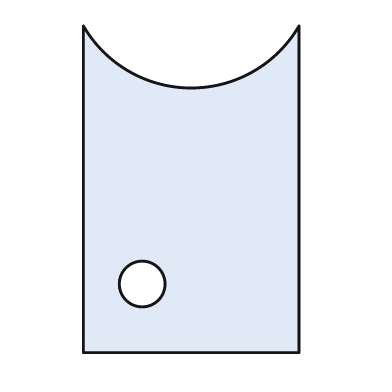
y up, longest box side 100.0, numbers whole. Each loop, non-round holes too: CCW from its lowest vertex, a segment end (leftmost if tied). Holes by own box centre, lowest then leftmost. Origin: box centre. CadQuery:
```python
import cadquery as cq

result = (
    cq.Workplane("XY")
    .moveTo(-33.0, -50.0)
    .lineTo(33.0, -50.0)
    .lineTo(33.0, 50.0)
    .threePointArc((0.0, 31.0), (-33.0, 50.0))
    .close()
    .moveTo(-15.0, -29.0)
    .circle(7.0)
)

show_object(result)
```